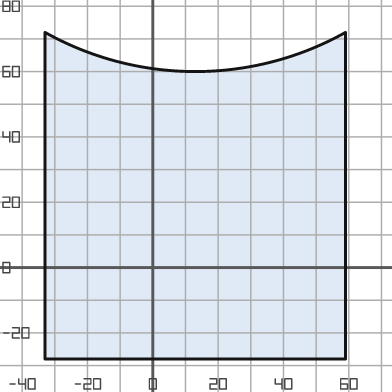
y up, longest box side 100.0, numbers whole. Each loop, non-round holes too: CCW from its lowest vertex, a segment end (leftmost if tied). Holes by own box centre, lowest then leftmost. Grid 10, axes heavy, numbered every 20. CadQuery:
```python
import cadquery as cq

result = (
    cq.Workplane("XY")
    .moveTo(-33.0, -28.0)
    .lineTo(59.0, -28.0)
    .lineTo(59.0, 72.0)
    .threePointArc((13.0, 60.0), (-33.0, 72.0))
    .close()
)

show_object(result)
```